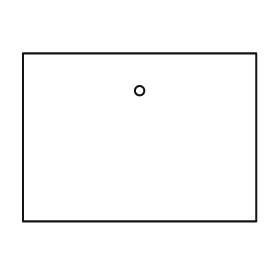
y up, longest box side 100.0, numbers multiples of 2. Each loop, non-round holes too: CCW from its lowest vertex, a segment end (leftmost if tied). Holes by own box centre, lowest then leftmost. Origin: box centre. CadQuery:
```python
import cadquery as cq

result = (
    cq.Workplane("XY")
    .moveTo(-50.0, -36.0)
    .lineTo(50.0, -36.0)
    .lineTo(50.0, 36.0)
    .lineTo(-50.0, 36.0)
    .close()
    .moveTo(0.0, 20.0)
    .circle(2.0)
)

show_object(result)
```